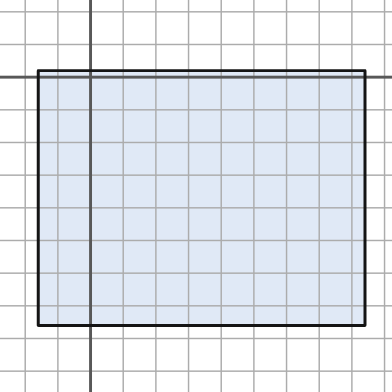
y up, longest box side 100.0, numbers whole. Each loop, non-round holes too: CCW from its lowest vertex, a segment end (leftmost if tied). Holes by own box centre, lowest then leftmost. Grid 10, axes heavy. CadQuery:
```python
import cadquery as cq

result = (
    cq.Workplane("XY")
    .moveTo(-16.0, -76.0)
    .lineTo(84.0, -76.0)
    .lineTo(84.0, 2.0)
    .lineTo(-16.0, 2.0)
    .close()
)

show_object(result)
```